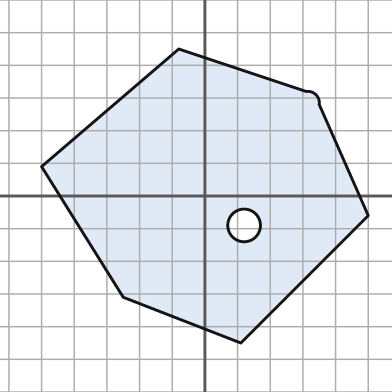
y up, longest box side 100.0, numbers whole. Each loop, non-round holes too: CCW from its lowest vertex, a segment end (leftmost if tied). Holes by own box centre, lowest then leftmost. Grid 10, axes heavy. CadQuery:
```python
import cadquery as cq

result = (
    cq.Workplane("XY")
    .moveTo(11.0, -45.0)
    .lineTo(50.0, -6.0)
    .lineTo(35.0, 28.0)
    .threePointArc((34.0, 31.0), (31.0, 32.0))
    .lineTo(-8.0, 45.0)
    .lineTo(-50.0, 9.0)
    .lineTo(-25.0, -31.0)
    .close()
    .moveTo(12.0, -9.0)
    .circle(5.0)
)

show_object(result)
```